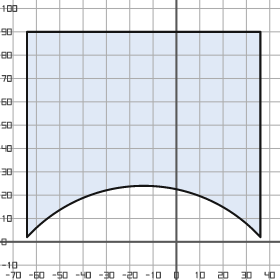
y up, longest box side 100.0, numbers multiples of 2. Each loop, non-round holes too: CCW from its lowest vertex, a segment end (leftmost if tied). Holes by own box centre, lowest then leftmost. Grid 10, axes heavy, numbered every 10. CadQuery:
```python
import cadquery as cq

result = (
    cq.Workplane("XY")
    .moveTo(-64.0, 2.0)
    .threePointArc((-14.0, 24.0), (36.0, 2.0))
    .lineTo(36.0, 90.0)
    .lineTo(-64.0, 90.0)
    .close()
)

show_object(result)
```